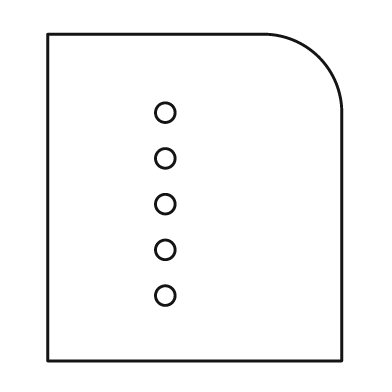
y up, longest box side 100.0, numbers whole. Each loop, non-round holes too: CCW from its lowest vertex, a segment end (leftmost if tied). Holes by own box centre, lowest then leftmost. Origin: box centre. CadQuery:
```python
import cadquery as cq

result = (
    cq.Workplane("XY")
    .moveTo(-45.0, -50.0)
    .lineTo(45.0, -50.0)
    .lineTo(45.0, 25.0)
    .threePointArc((38.0, 43.0), (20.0, 50.0))
    .lineTo(-45.0, 50.0)
    .close()
    .moveTo(-9.0, -30.0)
    .circle(3.0)
    .moveTo(-9.0, -16.0)
    .circle(3.0)
    .moveTo(-9.0, -2.0)
    .circle(3.0)
    .moveTo(-9.0, 12.0)
    .circle(3.0)
    .moveTo(-9.0, 26.0)
    .circle(3.0)
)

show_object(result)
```